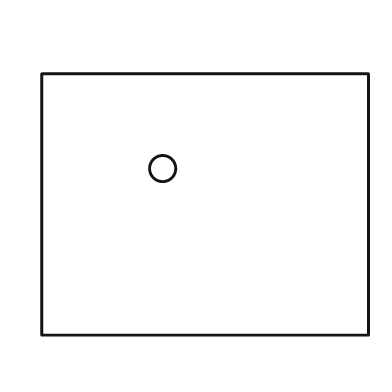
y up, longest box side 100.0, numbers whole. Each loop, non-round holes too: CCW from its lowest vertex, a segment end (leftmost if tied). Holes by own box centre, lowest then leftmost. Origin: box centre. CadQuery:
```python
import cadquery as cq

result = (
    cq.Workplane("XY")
    .moveTo(-50.0, -40.0)
    .lineTo(50.0, -40.0)
    .lineTo(50.0, 40.0)
    .lineTo(-50.0, 40.0)
    .close()
    .moveTo(-13.0, 11.0)
    .circle(4.0)
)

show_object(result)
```